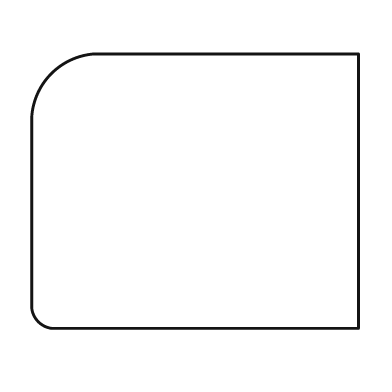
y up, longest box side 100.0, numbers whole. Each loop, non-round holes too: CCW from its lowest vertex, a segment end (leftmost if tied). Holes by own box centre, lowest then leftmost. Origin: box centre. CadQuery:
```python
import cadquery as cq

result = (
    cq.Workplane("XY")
    .moveTo(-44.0, -42.0)
    .lineTo(50.0, -42.0)
    .lineTo(50.0, 42.0)
    .lineTo(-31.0, 42.0)
    .threePointArc((-44.0, 36.0), (-50.0, 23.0))
    .lineTo(-50.0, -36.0)
    .threePointArc((-48.0, -40.0), (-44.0, -42.0))
    .close()
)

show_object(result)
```